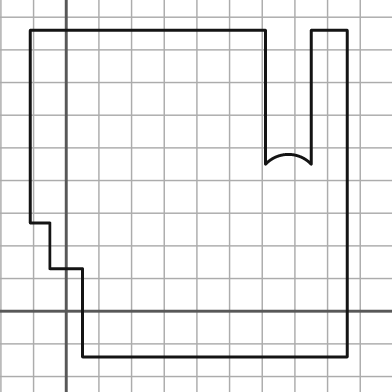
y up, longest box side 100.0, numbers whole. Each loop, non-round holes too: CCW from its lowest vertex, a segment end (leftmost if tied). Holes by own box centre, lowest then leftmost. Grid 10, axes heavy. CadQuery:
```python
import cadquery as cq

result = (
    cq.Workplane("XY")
    .moveTo(5.0, -14.0)
    .lineTo(86.0, -14.0)
    .lineTo(86.0, 86.0)
    .lineTo(75.0, 86.0)
    .lineTo(75.0, 45.0)
    .threePointArc((68.0, 48.0), (61.0, 45.0))
    .lineTo(61.0, 86.0)
    .lineTo(-11.0, 86.0)
    .lineTo(-11.0, 27.0)
    .lineTo(-5.0, 27.0)
    .lineTo(-5.0, 13.0)
    .lineTo(5.0, 13.0)
    .close()
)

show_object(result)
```